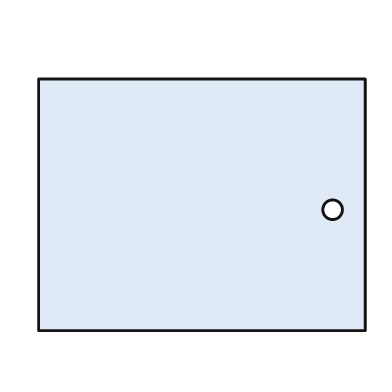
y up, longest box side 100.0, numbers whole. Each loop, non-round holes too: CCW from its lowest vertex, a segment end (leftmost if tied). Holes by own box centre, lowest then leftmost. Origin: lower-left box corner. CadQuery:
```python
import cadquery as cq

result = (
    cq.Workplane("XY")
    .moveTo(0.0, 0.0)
    .lineTo(100.0, 0.0)
    .lineTo(100.0, 77.0)
    .lineTo(0.0, 77.0)
    .close()
    .moveTo(90.0, 37.0)
    .circle(3.0)
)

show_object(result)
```